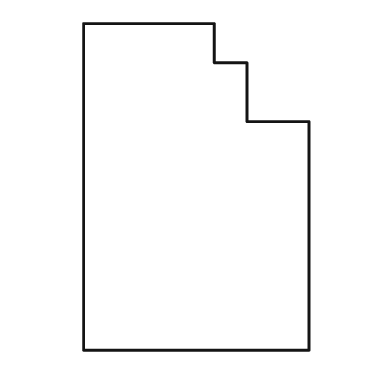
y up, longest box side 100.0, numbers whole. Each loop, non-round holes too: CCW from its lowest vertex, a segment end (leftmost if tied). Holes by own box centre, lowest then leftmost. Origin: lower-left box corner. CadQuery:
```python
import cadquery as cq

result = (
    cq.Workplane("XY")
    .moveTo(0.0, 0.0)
    .lineTo(69.0, 0.0)
    .lineTo(69.0, 70.0)
    .lineTo(50.0, 70.0)
    .lineTo(50.0, 88.0)
    .lineTo(40.0, 88.0)
    .lineTo(40.0, 100.0)
    .lineTo(0.0, 100.0)
    .close()
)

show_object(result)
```